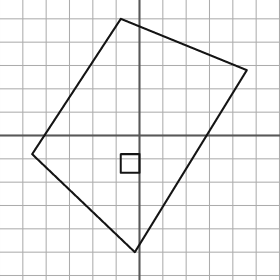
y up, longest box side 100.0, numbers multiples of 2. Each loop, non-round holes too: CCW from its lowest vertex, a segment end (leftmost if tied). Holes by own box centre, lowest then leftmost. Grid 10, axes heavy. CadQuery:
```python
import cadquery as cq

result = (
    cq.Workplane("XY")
    .moveTo(-2.0, -50.0)
    .lineTo(46.0, 28.0)
    .lineTo(-8.0, 50.0)
    .lineTo(-46.0, -8.0)
    .close()
    .moveTo(-8.0, -16.0)
    .lineTo(0.0, -16.0)
    .lineTo(0.0, -8.0)
    .lineTo(-8.0, -8.0)
    .close()
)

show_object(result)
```